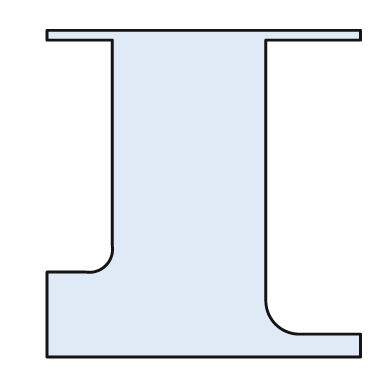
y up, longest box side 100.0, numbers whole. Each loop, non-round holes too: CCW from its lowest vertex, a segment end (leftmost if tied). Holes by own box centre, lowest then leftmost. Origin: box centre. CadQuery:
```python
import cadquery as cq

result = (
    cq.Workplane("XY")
    .moveTo(-48.0, -50.0)
    .lineTo(48.0, -50.0)
    .lineTo(48.0, -43.0)
    .lineTo(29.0, -43.0)
    .threePointArc((22.0, -40.0), (19.0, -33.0))
    .lineTo(19.0, 47.0)
    .lineTo(48.0, 47.0)
    .lineTo(48.0, 50.0)
    .lineTo(-48.0, 50.0)
    .lineTo(-48.0, 47.0)
    .lineTo(-28.0, 47.0)
    .lineTo(-28.0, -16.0)
    .threePointArc((-30.0, -22.0), (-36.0, -24.0))
    .lineTo(-48.0, -24.0)
    .close()
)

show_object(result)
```